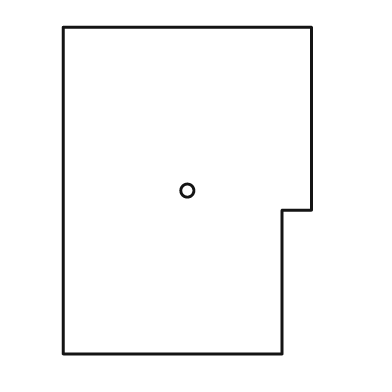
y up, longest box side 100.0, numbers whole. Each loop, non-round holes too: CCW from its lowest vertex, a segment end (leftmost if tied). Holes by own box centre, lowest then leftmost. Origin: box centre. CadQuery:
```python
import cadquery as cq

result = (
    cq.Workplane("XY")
    .moveTo(-38.0, -50.0)
    .lineTo(29.0, -50.0)
    .lineTo(29.0, -6.0)
    .lineTo(38.0, -6.0)
    .lineTo(38.0, 50.0)
    .lineTo(-38.0, 50.0)
    .close()
    .moveTo(0.0, 0.0)
    .circle(2.0)
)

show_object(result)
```